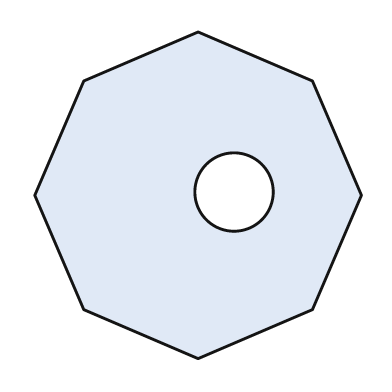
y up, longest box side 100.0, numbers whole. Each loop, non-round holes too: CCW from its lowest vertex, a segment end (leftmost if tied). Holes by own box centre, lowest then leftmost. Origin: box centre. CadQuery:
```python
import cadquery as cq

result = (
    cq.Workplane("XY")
    .moveTo(0.0, -50.0)
    .lineTo(35.0, -35.0)
    .lineTo(50.0, 0.0)
    .lineTo(35.0, 35.0)
    .lineTo(0.0, 50.0)
    .lineTo(-35.0, 35.0)
    .lineTo(-50.0, 0.0)
    .lineTo(-35.0, -35.0)
    .close()
    .moveTo(11.0, 1.0)
    .circle(12.0)
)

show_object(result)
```